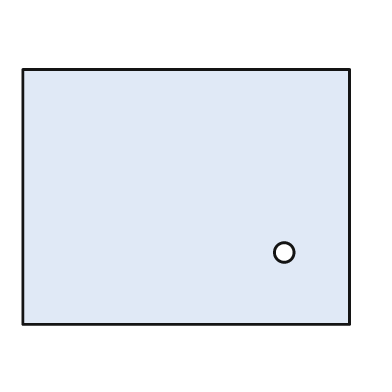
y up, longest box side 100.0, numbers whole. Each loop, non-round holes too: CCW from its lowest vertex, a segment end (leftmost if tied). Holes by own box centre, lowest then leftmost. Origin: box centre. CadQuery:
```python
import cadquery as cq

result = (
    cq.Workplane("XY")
    .moveTo(-50.0, -39.0)
    .lineTo(50.0, -39.0)
    .lineTo(50.0, 39.0)
    .lineTo(-50.0, 39.0)
    .close()
    .moveTo(30.0, -17.0)
    .circle(3.0)
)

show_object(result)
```